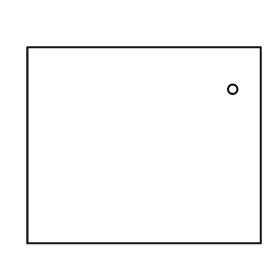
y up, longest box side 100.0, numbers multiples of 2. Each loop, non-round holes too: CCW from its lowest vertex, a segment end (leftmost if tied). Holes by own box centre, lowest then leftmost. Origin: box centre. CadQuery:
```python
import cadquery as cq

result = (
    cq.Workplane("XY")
    .moveTo(-50.0, -42.0)
    .lineTo(50.0, -42.0)
    .lineTo(50.0, 42.0)
    .lineTo(-50.0, 42.0)
    .close()
    .moveTo(38.0, 24.0)
    .circle(2.0)
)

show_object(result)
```